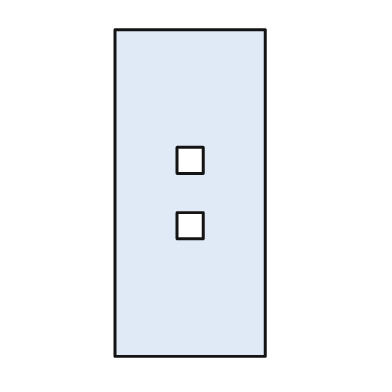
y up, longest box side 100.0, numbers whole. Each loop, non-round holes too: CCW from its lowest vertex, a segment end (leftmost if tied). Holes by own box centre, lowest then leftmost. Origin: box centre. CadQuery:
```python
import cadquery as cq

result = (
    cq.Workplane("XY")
    .moveTo(-23.0, -50.0)
    .lineTo(23.0, -50.0)
    .lineTo(23.0, 50.0)
    .lineTo(-23.0, 50.0)
    .close()
    .moveTo(-4.0, -14.0)
    .lineTo(4.0, -14.0)
    .lineTo(4.0, -6.0)
    .lineTo(-4.0, -6.0)
    .close()
    .moveTo(-4.0, 6.0)
    .lineTo(4.0, 6.0)
    .lineTo(4.0, 14.0)
    .lineTo(-4.0, 14.0)
    .close()
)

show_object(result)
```